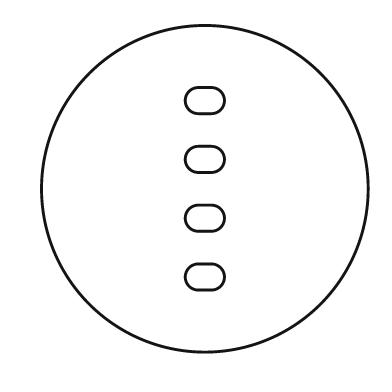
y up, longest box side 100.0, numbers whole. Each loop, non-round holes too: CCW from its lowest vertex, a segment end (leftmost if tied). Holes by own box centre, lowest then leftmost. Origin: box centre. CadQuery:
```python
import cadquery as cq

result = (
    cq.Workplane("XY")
    .moveTo(0.0, 0.0)
    .circle(50.0)
    .moveTo(-2.0, -31.0)
    .lineTo(2.0, -31.0)
    .threePointArc((6.0, -27.0), (2.0, -23.0))
    .lineTo(-2.0, -23.0)
    .threePointArc((-6.0, -27.0), (-2.0, -31.0))
    .close()
    .moveTo(-2.0, -13.0)
    .lineTo(2.0, -13.0)
    .threePointArc((6.0, -9.0), (2.0, -5.0))
    .lineTo(-2.0, -5.0)
    .threePointArc((-6.0, -9.0), (-2.0, -13.0))
    .close()
    .moveTo(-2.0, 5.0)
    .lineTo(2.0, 5.0)
    .threePointArc((6.0, 9.0), (2.0, 13.0))
    .lineTo(-2.0, 13.0)
    .threePointArc((-6.0, 9.0), (-2.0, 5.0))
    .close()
    .moveTo(-2.0, 23.0)
    .lineTo(2.0, 23.0)
    .threePointArc((6.0, 27.0), (2.0, 31.0))
    .lineTo(-2.0, 31.0)
    .threePointArc((-6.0, 27.0), (-2.0, 23.0))
    .close()
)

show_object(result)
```